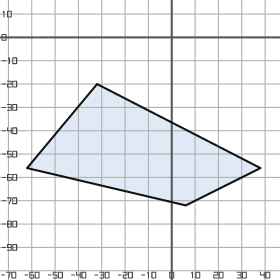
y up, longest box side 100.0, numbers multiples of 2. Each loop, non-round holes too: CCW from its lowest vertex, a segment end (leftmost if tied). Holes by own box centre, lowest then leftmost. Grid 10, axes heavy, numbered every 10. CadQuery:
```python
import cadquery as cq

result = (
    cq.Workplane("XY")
    .moveTo(6.0, -72.0)
    .lineTo(38.0, -56.0)
    .lineTo(-32.0, -20.0)
    .lineTo(-62.0, -56.0)
    .close()
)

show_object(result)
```